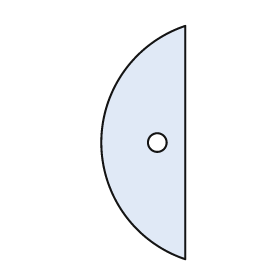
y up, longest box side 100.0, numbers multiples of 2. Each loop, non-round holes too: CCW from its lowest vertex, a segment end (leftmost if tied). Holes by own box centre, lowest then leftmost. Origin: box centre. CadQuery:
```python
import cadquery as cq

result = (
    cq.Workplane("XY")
    .moveTo(18.0, -50.0)
    .lineTo(18.0, 50.0)
    .threePointArc((-18.0, 0.0), (18.0, -50.0))
    .close()
    .moveTo(6.0, 0.0)
    .circle(4.0)
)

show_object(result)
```